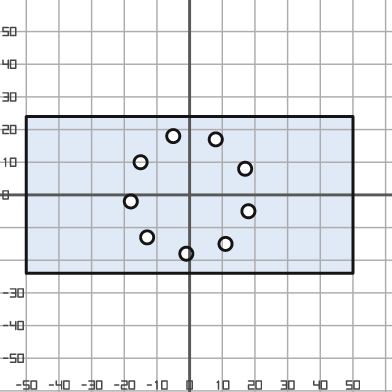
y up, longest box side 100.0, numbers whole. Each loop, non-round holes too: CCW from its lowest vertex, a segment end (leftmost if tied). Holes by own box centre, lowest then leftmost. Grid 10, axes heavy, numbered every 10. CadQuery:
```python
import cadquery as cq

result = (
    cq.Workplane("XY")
    .moveTo(-50.0, -24.0)
    .lineTo(50.0, -24.0)
    .lineTo(50.0, 24.0)
    .lineTo(-50.0, 24.0)
    .close()
    .moveTo(-1.0, -18.0)
    .circle(2.0)
    .moveTo(11.0, -15.0)
    .circle(2.0)
    .moveTo(-13.0, -13.0)
    .circle(2.0)
    .moveTo(18.0, -5.0)
    .circle(2.0)
    .moveTo(-18.0, -2.0)
    .circle(2.0)
    .moveTo(17.0, 8.0)
    .circle(2.0)
    .moveTo(-15.0, 10.0)
    .circle(2.0)
    .moveTo(8.0, 17.0)
    .circle(2.0)
    .moveTo(-5.0, 18.0)
    .circle(2.0)
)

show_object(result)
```